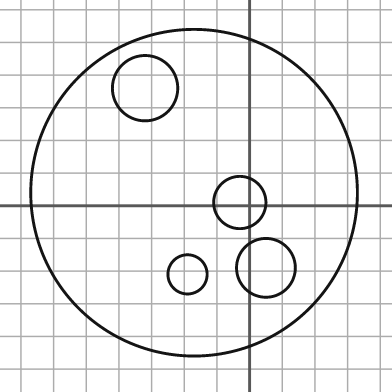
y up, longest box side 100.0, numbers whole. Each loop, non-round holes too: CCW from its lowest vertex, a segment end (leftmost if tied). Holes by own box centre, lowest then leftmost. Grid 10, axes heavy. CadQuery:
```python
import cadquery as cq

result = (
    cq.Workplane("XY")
    .moveTo(-17.0, 4.0)
    .circle(50.0)
    .moveTo(-19.0, -21.0)
    .circle(6.0)
    .moveTo(5.0, -19.0)
    .circle(9.0)
    .moveTo(-3.0, 1.0)
    .circle(8.0)
    .moveTo(-32.0, 36.0)
    .circle(10.0)
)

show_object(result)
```